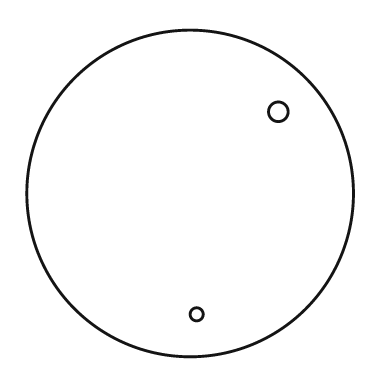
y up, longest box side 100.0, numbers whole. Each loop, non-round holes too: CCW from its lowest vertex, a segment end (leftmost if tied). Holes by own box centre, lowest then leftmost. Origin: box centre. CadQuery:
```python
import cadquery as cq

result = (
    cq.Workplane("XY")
    .moveTo(0.0, 0.0)
    .circle(50.0)
    .moveTo(2.0, -37.0)
    .circle(2.0)
    .moveTo(27.0, 25.0)
    .circle(3.0)
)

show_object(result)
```